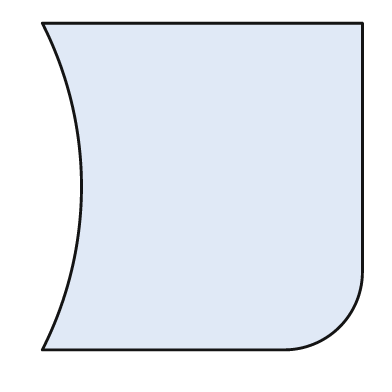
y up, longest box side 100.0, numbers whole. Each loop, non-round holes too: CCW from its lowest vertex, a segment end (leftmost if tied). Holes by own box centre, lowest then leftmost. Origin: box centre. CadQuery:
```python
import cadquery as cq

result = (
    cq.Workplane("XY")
    .moveTo(-49.0, -50.0)
    .lineTo(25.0, -50.0)
    .threePointArc((42.0, -43.0), (49.0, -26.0))
    .lineTo(49.0, 50.0)
    .lineTo(-49.0, 50.0)
    .threePointArc((-37.0, 0.0), (-49.0, -50.0))
    .close()
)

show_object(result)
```